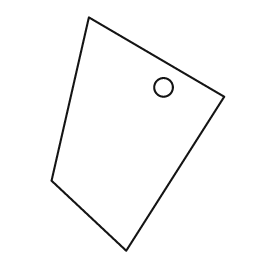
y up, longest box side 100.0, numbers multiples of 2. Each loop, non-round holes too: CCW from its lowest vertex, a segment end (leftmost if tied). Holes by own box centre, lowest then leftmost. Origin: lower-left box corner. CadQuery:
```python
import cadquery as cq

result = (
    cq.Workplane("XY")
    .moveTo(32.0, 0.0)
    .lineTo(74.0, 66.0)
    .lineTo(16.0, 100.0)
    .lineTo(0.0, 30.0)
    .close()
    .moveTo(48.0, 70.0)
    .circle(4.0)
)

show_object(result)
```